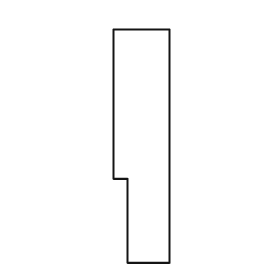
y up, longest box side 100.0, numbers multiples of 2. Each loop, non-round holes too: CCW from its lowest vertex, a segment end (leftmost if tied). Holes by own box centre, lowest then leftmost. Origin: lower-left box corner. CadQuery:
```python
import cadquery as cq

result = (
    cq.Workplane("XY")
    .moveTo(6.0, 0.0)
    .lineTo(24.0, 0.0)
    .lineTo(24.0, 100.0)
    .lineTo(0.0, 100.0)
    .lineTo(0.0, 36.0)
    .lineTo(6.0, 36.0)
    .close()
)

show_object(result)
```